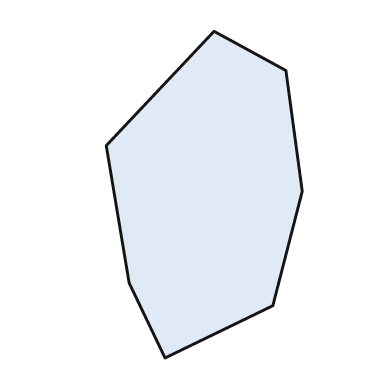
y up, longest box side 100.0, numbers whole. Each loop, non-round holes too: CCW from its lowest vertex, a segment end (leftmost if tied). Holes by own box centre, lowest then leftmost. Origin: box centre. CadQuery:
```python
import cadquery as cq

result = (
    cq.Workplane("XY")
    .moveTo(-12.0, -50.0)
    .lineTo(21.0, -34.0)
    .lineTo(30.0, 1.0)
    .lineTo(25.0, 38.0)
    .lineTo(3.0, 50.0)
    .lineTo(-30.0, 15.0)
    .lineTo(-23.0, -27.0)
    .close()
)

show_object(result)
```